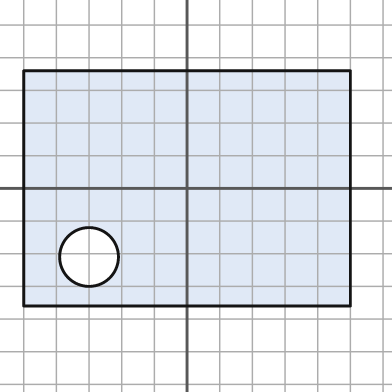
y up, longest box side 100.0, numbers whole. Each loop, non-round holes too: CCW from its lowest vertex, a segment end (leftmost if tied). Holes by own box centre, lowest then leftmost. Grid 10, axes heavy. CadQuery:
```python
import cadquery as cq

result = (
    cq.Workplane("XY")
    .moveTo(-50.0, -36.0)
    .lineTo(50.0, -36.0)
    .lineTo(50.0, 36.0)
    .lineTo(-50.0, 36.0)
    .close()
    .moveTo(-30.0, -21.0)
    .circle(9.0)
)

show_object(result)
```